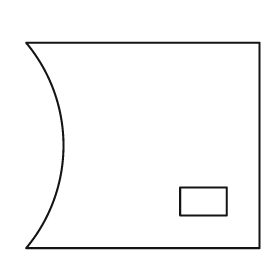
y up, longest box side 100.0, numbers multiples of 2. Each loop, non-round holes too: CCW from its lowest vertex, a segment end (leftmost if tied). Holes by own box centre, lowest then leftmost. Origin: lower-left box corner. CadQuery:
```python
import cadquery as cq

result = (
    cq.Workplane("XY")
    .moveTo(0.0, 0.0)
    .lineTo(100.0, 0.0)
    .lineTo(100.0, 88.0)
    .lineTo(0.0, 88.0)
    .threePointArc((16.0, 44.0), (0.0, 0.0))
    .close()
    .moveTo(66.0, 14.0)
    .lineTo(86.0, 14.0)
    .lineTo(86.0, 26.0)
    .lineTo(66.0, 26.0)
    .close()
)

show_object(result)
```